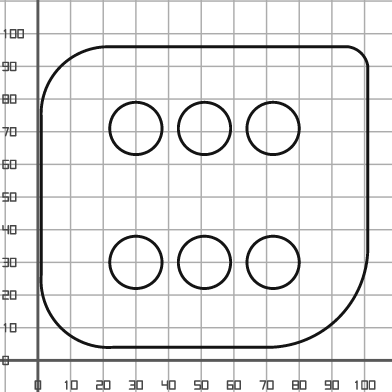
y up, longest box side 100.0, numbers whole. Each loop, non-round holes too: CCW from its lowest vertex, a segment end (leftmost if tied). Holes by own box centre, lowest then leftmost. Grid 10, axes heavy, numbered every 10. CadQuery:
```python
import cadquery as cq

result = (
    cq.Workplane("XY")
    .moveTo(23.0, 4.0)
    .lineTo(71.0, 4.0)
    .threePointArc((92.0, 13.0), (101.0, 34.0))
    .lineTo(101.0, 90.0)
    .threePointArc((99.0, 94.0), (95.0, 96.0))
    .lineTo(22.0, 96.0)
    .threePointArc((7.0, 90.0), (1.0, 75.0))
    .lineTo(1.0, 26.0)
    .threePointArc((7.0, 10.0), (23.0, 4.0))
    .close()
    .moveTo(30.0, 30.0)
    .circle(8.0)
    .moveTo(51.0, 30.0)
    .circle(8.0)
    .moveTo(72.0, 30.0)
    .circle(8.0)
    .moveTo(30.0, 71.0)
    .circle(8.0)
    .moveTo(51.0, 71.0)
    .circle(8.0)
    .moveTo(72.0, 71.0)
    .circle(8.0)
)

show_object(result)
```